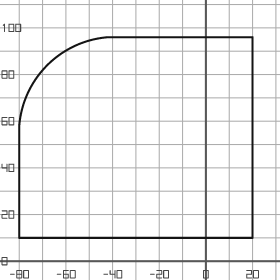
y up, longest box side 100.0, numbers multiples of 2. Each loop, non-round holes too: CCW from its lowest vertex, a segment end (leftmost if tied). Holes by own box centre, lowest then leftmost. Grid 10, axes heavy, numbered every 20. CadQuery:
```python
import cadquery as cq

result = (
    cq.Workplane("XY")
    .moveTo(-80.0, 10.0)
    .lineTo(20.0, 10.0)
    .lineTo(20.0, 96.0)
    .lineTo(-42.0, 96.0)
    .threePointArc((-68.0, 84.0), (-80.0, 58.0))
    .close()
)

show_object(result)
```